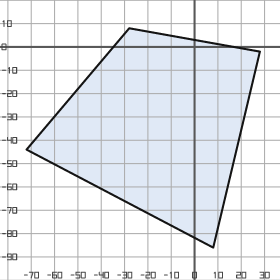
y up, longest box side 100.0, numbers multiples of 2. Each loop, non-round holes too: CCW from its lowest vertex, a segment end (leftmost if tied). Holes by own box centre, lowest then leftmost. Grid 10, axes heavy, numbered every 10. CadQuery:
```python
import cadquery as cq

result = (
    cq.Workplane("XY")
    .moveTo(8.0, -86.0)
    .lineTo(28.0, -2.0)
    .lineTo(-28.0, 8.0)
    .lineTo(-72.0, -44.0)
    .close()
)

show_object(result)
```